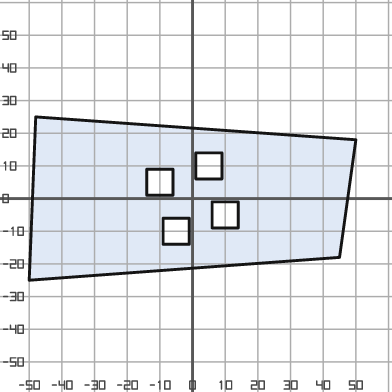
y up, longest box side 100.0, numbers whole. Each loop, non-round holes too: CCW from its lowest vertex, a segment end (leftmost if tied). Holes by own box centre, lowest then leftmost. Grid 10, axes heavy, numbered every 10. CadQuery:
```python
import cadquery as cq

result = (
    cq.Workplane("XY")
    .moveTo(-50.0, -25.0)
    .lineTo(45.0, -18.0)
    .lineTo(50.0, 18.0)
    .lineTo(-48.0, 25.0)
    .close()
    .moveTo(-9.0, -14.0)
    .lineTo(-1.0, -14.0)
    .lineTo(-1.0, -6.0)
    .lineTo(-9.0, -6.0)
    .close()
    .moveTo(6.0, -9.0)
    .lineTo(14.0, -9.0)
    .lineTo(14.0, -1.0)
    .lineTo(6.0, -1.0)
    .close()
    .moveTo(-14.0, 1.0)
    .lineTo(-6.0, 1.0)
    .lineTo(-6.0, 9.0)
    .lineTo(-14.0, 9.0)
    .close()
    .moveTo(1.0, 6.0)
    .lineTo(9.0, 6.0)
    .lineTo(9.0, 14.0)
    .lineTo(1.0, 14.0)
    .close()
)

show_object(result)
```